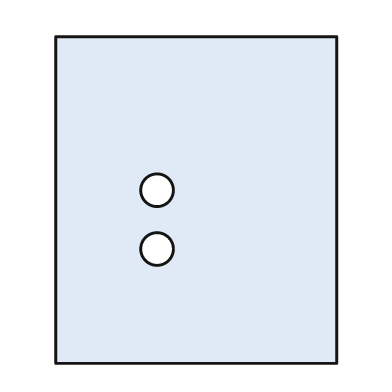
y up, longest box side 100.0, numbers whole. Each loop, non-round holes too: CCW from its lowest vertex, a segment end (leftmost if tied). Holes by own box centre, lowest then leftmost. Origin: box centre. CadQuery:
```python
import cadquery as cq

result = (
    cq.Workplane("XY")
    .moveTo(-43.0, -50.0)
    .lineTo(43.0, -50.0)
    .lineTo(43.0, 50.0)
    .lineTo(-43.0, 50.0)
    .close()
    .moveTo(-12.0, -15.0)
    .circle(5.0)
    .moveTo(-12.0, 3.0)
    .circle(5.0)
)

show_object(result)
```